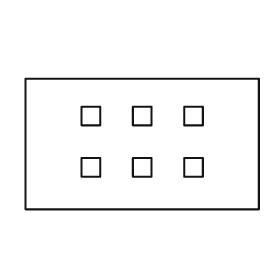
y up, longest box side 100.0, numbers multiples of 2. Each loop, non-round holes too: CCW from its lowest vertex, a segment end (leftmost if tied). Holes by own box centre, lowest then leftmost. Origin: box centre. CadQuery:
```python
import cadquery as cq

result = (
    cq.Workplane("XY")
    .moveTo(-50.0, -28.0)
    .lineTo(50.0, -28.0)
    .lineTo(50.0, 28.0)
    .lineTo(-50.0, 28.0)
    .close()
    .moveTo(-26.0, -14.0)
    .lineTo(-18.0, -14.0)
    .lineTo(-18.0, -6.0)
    .lineTo(-26.0, -6.0)
    .close()
    .moveTo(-4.0, -14.0)
    .lineTo(4.0, -14.0)
    .lineTo(4.0, -6.0)
    .lineTo(-4.0, -6.0)
    .close()
    .moveTo(18.0, -14.0)
    .lineTo(26.0, -14.0)
    .lineTo(26.0, -6.0)
    .lineTo(18.0, -6.0)
    .close()
    .moveTo(-26.0, 8.0)
    .lineTo(-18.0, 8.0)
    .lineTo(-18.0, 16.0)
    .lineTo(-26.0, 16.0)
    .close()
    .moveTo(-4.0, 8.0)
    .lineTo(4.0, 8.0)
    .lineTo(4.0, 16.0)
    .lineTo(-4.0, 16.0)
    .close()
    .moveTo(18.0, 8.0)
    .lineTo(26.0, 8.0)
    .lineTo(26.0, 16.0)
    .lineTo(18.0, 16.0)
    .close()
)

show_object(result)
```